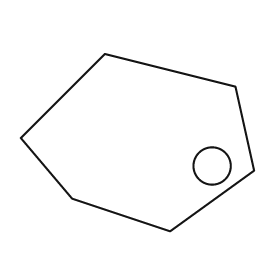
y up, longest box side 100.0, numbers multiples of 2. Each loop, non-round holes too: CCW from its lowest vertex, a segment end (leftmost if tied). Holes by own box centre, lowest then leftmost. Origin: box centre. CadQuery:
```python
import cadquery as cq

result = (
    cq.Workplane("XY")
    .moveTo(14.0, -38.0)
    .lineTo(50.0, -12.0)
    .lineTo(42.0, 24.0)
    .lineTo(-14.0, 38.0)
    .lineTo(-50.0, 2.0)
    .lineTo(-28.0, -24.0)
    .close()
    .moveTo(32.0, -10.0)
    .circle(8.0)
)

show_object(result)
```